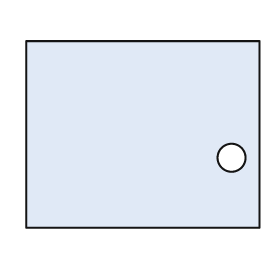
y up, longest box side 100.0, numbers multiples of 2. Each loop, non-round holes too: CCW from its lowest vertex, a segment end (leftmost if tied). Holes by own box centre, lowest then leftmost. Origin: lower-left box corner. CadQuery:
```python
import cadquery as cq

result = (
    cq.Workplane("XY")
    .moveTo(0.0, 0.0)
    .lineTo(100.0, 0.0)
    .lineTo(100.0, 80.0)
    .lineTo(0.0, 80.0)
    .close()
    .moveTo(88.0, 30.0)
    .circle(6.0)
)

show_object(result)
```